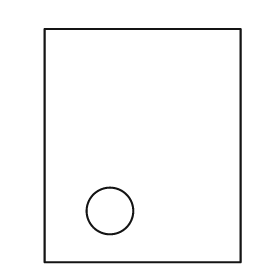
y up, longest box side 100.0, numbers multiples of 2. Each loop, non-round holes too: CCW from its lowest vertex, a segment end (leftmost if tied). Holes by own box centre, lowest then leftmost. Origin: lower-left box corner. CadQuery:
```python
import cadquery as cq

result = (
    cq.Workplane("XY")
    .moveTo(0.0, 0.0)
    .lineTo(84.0, 0.0)
    .lineTo(84.0, 100.0)
    .lineTo(0.0, 100.0)
    .close()
    .moveTo(28.0, 22.0)
    .circle(10.0)
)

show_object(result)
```